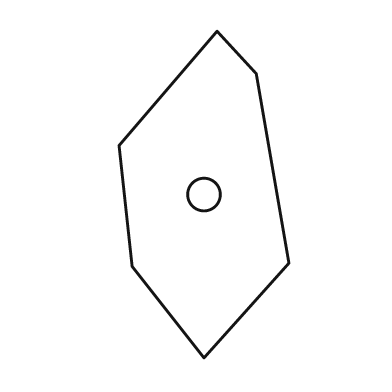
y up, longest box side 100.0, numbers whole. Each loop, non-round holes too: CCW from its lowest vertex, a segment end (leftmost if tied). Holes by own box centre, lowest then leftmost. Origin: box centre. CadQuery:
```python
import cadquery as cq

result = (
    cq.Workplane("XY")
    .moveTo(0.0, -50.0)
    .lineTo(26.0, -21.0)
    .lineTo(16.0, 37.0)
    .lineTo(4.0, 50.0)
    .lineTo(-26.0, 15.0)
    .lineTo(-22.0, -22.0)
    .close()
    .moveTo(0.0, 0.0)
    .circle(5.0)
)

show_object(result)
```